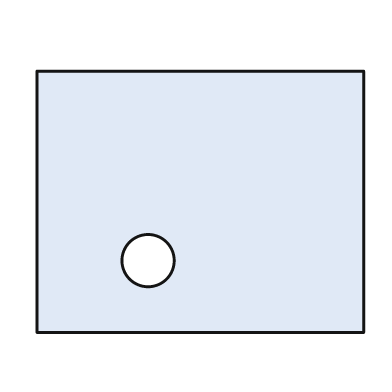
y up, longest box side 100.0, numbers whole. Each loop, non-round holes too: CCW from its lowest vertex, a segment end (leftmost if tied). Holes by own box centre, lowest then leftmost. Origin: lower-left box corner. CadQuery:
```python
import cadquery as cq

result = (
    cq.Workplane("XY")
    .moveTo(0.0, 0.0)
    .lineTo(100.0, 0.0)
    .lineTo(100.0, 80.0)
    .lineTo(0.0, 80.0)
    .close()
    .moveTo(34.0, 22.0)
    .circle(8.0)
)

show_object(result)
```